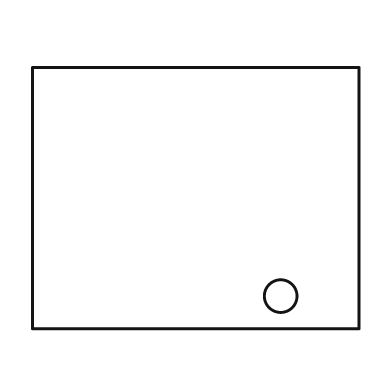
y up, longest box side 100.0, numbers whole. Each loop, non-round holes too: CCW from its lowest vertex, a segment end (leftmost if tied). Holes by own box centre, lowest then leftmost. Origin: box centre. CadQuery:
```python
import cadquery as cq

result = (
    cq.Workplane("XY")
    .moveTo(-50.0, -40.0)
    .lineTo(50.0, -40.0)
    .lineTo(50.0, 40.0)
    .lineTo(-50.0, 40.0)
    .close()
    .moveTo(26.0, -30.0)
    .circle(5.0)
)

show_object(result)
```